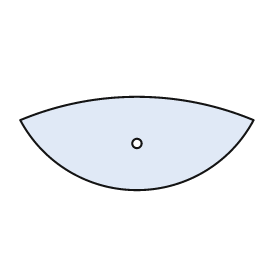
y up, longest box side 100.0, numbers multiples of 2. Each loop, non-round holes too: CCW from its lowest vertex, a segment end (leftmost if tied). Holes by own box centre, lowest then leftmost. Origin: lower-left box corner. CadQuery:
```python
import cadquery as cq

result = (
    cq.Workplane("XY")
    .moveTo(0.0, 30.0)
    .threePointArc((50.0, 0.0), (100.0, 30.0))
    .threePointArc((50.0, 40.0), (0.0, 30.0))
    .close()
    .moveTo(50.0, 20.0)
    .circle(2.0)
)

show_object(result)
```